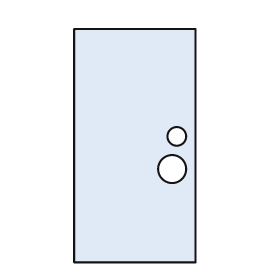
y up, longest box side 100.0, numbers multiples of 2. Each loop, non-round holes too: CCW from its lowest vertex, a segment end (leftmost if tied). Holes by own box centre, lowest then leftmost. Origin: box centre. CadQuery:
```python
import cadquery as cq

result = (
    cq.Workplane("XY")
    .moveTo(-26.0, -50.0)
    .lineTo(26.0, -50.0)
    .lineTo(26.0, 50.0)
    .lineTo(-26.0, 50.0)
    .close()
    .moveTo(16.0, -10.0)
    .circle(6.0)
    .moveTo(18.0, 4.0)
    .circle(4.0)
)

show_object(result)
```